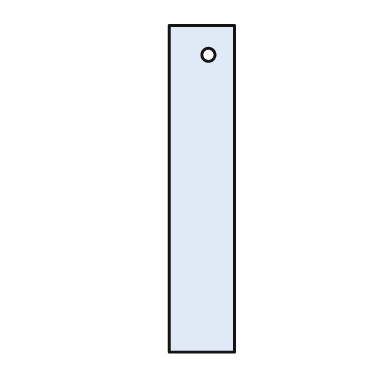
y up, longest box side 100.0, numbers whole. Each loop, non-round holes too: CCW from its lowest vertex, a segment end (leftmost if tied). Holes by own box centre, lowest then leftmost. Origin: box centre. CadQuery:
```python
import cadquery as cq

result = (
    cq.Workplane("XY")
    .moveTo(-10.0, -50.0)
    .lineTo(10.0, -50.0)
    .lineTo(10.0, 50.0)
    .lineTo(-10.0, 50.0)
    .close()
    .moveTo(2.0, 41.0)
    .circle(2.0)
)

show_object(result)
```